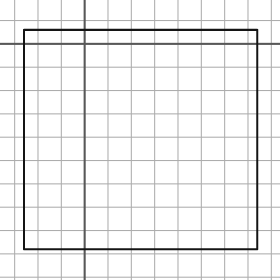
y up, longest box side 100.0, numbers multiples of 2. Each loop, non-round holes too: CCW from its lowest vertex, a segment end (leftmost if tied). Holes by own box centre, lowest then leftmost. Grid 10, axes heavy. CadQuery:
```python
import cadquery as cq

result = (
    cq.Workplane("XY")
    .moveTo(-26.0, -88.0)
    .lineTo(74.0, -88.0)
    .lineTo(74.0, 6.0)
    .lineTo(-26.0, 6.0)
    .close()
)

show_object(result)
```